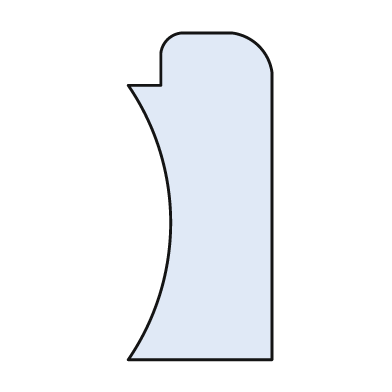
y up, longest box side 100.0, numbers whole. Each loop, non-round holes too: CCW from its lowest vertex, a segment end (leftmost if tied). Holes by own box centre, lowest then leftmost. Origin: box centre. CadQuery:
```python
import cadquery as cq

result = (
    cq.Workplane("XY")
    .moveTo(-22.0, -50.0)
    .lineTo(22.0, -50.0)
    .lineTo(22.0, 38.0)
    .threePointArc((18.0, 46.0), (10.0, 50.0))
    .lineTo(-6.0, 50.0)
    .threePointArc((-10.0, 48.0), (-12.0, 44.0))
    .lineTo(-12.0, 34.0)
    .lineTo(-22.0, 34.0)
    .threePointArc((-9.0, -8.0), (-22.0, -50.0))
    .close()
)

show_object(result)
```